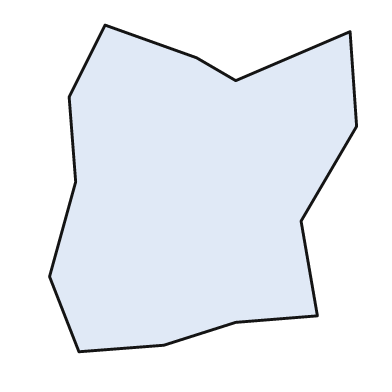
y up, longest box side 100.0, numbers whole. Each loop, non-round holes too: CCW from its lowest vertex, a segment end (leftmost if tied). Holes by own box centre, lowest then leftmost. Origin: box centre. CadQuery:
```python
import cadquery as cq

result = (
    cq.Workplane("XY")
    .moveTo(-38.0, -50.0)
    .lineTo(-12.0, -48.0)
    .lineTo(10.0, -41.0)
    .lineTo(35.0, -39.0)
    .lineTo(30.0, -10.0)
    .lineTo(47.0, 19.0)
    .lineTo(45.0, 48.0)
    .lineTo(10.0, 33.0)
    .lineTo(-2.0, 40.0)
    .lineTo(-30.0, 50.0)
    .lineTo(-41.0, 28.0)
    .lineTo(-39.0, 2.0)
    .lineTo(-47.0, -27.0)
    .close()
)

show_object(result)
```